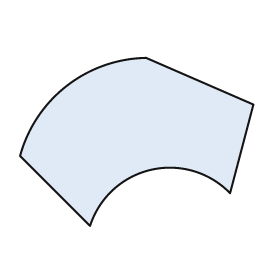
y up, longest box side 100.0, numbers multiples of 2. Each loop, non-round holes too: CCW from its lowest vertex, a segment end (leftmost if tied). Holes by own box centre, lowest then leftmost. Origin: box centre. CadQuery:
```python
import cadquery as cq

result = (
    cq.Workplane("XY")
    .moveTo(-20.0, -36.0)
    .threePointArc((6.0, -12.0), (40.0, -22.0))
    .lineTo(50.0, 16.0)
    .lineTo(4.0, 36.0)
    .threePointArc((-30.0, 24.0), (-50.0, -6.0))
    .close()
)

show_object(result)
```